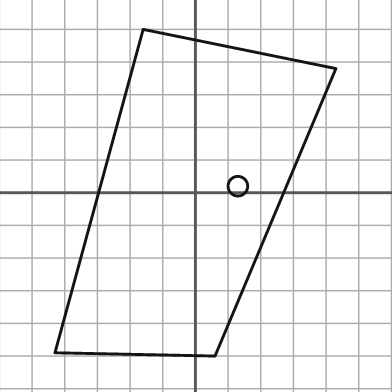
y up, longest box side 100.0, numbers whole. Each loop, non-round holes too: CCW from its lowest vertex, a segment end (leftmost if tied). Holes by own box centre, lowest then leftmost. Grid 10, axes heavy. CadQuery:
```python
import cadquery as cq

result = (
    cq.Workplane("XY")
    .moveTo(6.0, -50.0)
    .lineTo(43.0, 38.0)
    .lineTo(-16.0, 50.0)
    .lineTo(-43.0, -49.0)
    .close()
    .moveTo(13.0, 2.0)
    .circle(3.0)
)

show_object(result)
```